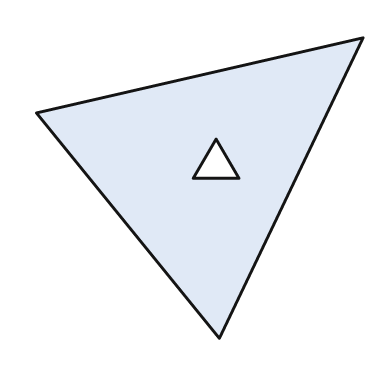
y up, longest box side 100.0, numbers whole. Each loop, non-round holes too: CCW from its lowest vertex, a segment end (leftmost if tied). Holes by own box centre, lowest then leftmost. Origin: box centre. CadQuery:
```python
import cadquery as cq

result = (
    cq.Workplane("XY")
    .moveTo(6.0, -46.0)
    .lineTo(50.0, 46.0)
    .lineTo(-50.0, 23.0)
    .close()
    .moveTo(-2.0, 3.0)
    .lineTo(12.0, 3.0)
    .lineTo(5.0, 15.0)
    .close()
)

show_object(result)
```